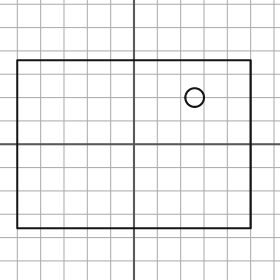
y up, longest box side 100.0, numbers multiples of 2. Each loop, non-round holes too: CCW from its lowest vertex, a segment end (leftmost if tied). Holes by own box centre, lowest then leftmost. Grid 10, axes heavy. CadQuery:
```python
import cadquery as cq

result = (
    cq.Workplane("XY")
    .moveTo(-50.0, -36.0)
    .lineTo(50.0, -36.0)
    .lineTo(50.0, 36.0)
    .lineTo(-50.0, 36.0)
    .close()
    .moveTo(26.0, 20.0)
    .circle(4.0)
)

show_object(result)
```